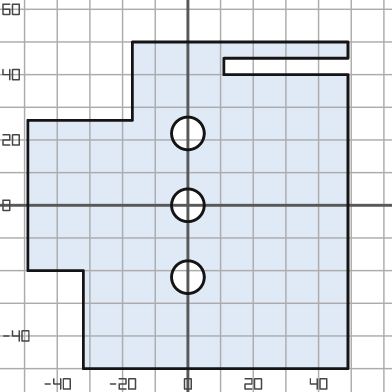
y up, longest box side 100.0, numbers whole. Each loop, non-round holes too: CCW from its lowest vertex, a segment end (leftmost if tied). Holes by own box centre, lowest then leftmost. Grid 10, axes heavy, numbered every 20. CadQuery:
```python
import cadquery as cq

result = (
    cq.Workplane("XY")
    .moveTo(-32.0, -50.0)
    .lineTo(49.0, -50.0)
    .lineTo(49.0, 40.0)
    .lineTo(11.0, 40.0)
    .lineTo(11.0, 45.0)
    .lineTo(49.0, 45.0)
    .lineTo(49.0, 50.0)
    .lineTo(-17.0, 50.0)
    .lineTo(-17.0, 26.0)
    .lineTo(-49.0, 26.0)
    .lineTo(-49.0, -20.0)
    .lineTo(-32.0, -20.0)
    .close()
    .moveTo(0.0, -22.0)
    .circle(5.0)
    .moveTo(0.0, 0.0)
    .circle(5.0)
    .moveTo(0.0, 22.0)
    .circle(5.0)
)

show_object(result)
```